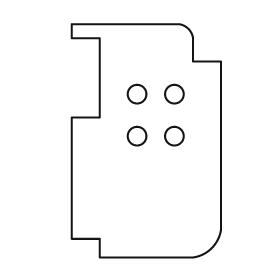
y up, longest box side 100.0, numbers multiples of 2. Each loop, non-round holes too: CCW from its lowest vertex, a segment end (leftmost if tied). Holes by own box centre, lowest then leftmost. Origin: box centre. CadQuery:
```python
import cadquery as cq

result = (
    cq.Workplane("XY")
    .moveTo(-20.0, -50.0)
    .lineTo(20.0, -50.0)
    .threePointArc((28.0, -46.0), (32.0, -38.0))
    .lineTo(32.0, 34.0)
    .lineTo(20.0, 34.0)
    .lineTo(20.0, 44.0)
    .threePointArc((18.0, 48.0), (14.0, 50.0))
    .lineTo(-32.0, 50.0)
    .lineTo(-32.0, 44.0)
    .lineTo(-20.0, 44.0)
    .lineTo(-20.0, 10.0)
    .lineTo(-32.0, 10.0)
    .lineTo(-32.0, -42.0)
    .lineTo(-20.0, -42.0)
    .close()
    .moveTo(-4.0, 2.0)
    .circle(4.0)
    .moveTo(12.0, 2.0)
    .circle(4.0)
    .moveTo(-4.0, 20.0)
    .circle(4.0)
    .moveTo(12.0, 20.0)
    .circle(4.0)
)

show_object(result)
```